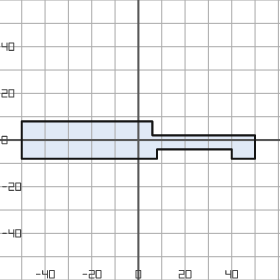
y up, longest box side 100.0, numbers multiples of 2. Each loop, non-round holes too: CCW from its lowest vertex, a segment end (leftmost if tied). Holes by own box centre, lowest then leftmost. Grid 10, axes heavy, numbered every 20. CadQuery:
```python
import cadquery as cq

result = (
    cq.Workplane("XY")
    .moveTo(-50.0, -8.0)
    .lineTo(8.0, -8.0)
    .lineTo(8.0, -4.0)
    .lineTo(40.0, -4.0)
    .lineTo(40.0, -8.0)
    .lineTo(50.0, -8.0)
    .lineTo(50.0, 2.0)
    .lineTo(6.0, 2.0)
    .lineTo(6.0, 8.0)
    .lineTo(-50.0, 8.0)
    .close()
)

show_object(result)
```